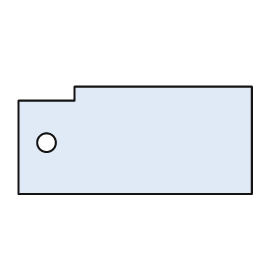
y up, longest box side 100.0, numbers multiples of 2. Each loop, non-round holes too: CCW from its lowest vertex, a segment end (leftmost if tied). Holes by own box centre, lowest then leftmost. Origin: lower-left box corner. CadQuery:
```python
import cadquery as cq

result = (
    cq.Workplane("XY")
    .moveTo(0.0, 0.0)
    .lineTo(100.0, 0.0)
    .lineTo(100.0, 46.0)
    .lineTo(24.0, 46.0)
    .lineTo(24.0, 40.0)
    .lineTo(0.0, 40.0)
    .close()
    .moveTo(12.0, 22.0)
    .circle(4.0)
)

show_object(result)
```